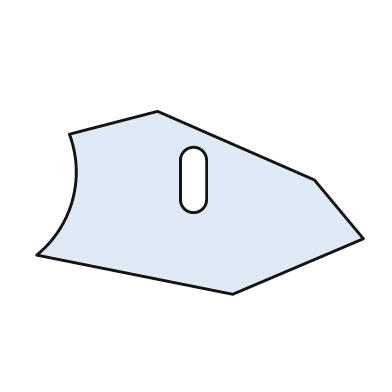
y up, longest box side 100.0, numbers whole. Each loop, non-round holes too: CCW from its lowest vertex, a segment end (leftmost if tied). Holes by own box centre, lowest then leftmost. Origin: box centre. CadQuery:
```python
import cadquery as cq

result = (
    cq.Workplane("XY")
    .moveTo(10.0, -28.0)
    .lineTo(50.0, -11.0)
    .lineTo(35.0, 7.0)
    .lineTo(-13.0, 28.0)
    .lineTo(-40.0, 21.0)
    .threePointArc((-39.0, 1.0), (-50.0, -16.0))
    .close()
    .moveTo(-6.0, 1.0)
    .threePointArc((-2.0, -3.0), (2.0, 1.0))
    .lineTo(2.0, 13.0)
    .threePointArc((-2.0, 17.0), (-6.0, 13.0))
    .close()
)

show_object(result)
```